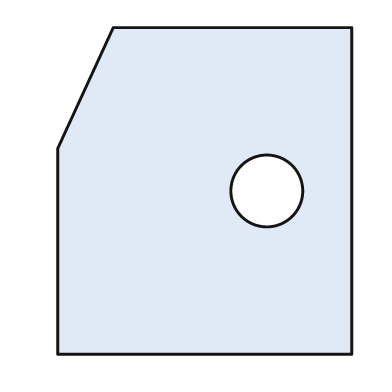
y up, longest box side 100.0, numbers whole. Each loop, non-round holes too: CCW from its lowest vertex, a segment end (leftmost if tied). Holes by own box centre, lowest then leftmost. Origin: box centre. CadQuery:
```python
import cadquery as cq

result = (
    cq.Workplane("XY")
    .moveTo(-45.0, -50.0)
    .lineTo(45.0, -50.0)
    .lineTo(45.0, 50.0)
    .lineTo(-28.0, 50.0)
    .lineTo(-45.0, 13.0)
    .close()
    .moveTo(19.0, 0.0)
    .circle(11.0)
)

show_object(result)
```